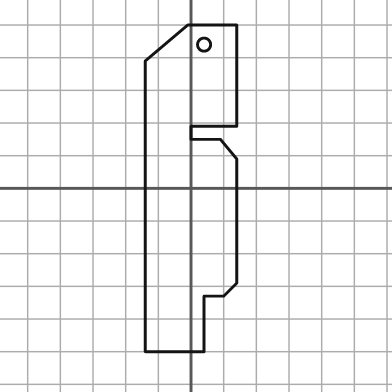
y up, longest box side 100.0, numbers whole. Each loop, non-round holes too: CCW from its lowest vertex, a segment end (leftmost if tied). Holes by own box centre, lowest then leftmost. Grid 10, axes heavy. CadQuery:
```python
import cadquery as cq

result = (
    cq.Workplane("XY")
    .moveTo(-14.0, -50.0)
    .lineTo(4.0, -50.0)
    .lineTo(4.0, -33.0)
    .lineTo(10.0, -33.0)
    .lineTo(14.0, -29.0)
    .lineTo(14.0, 9.0)
    .lineTo(9.0, 15.0)
    .lineTo(0.0, 15.0)
    .lineTo(0.0, 19.0)
    .lineTo(14.0, 19.0)
    .lineTo(14.0, 50.0)
    .lineTo(-1.0, 50.0)
    .lineTo(-14.0, 39.0)
    .close()
    .moveTo(4.0, 44.0)
    .circle(2.0)
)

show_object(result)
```